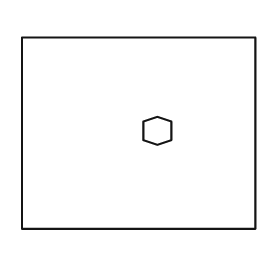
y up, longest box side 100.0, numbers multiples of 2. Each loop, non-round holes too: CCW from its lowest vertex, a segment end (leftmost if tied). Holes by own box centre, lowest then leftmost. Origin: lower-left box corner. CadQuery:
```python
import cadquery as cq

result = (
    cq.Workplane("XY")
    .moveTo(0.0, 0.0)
    .lineTo(100.0, 0.0)
    .lineTo(100.0, 82.0)
    .lineTo(0.0, 82.0)
    .close()
    .moveTo(58.0, 36.0)
    .lineTo(64.0, 38.0)
    .lineTo(64.0, 46.0)
    .lineTo(58.0, 48.0)
    .lineTo(52.0, 46.0)
    .lineTo(52.0, 38.0)
    .close()
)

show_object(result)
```